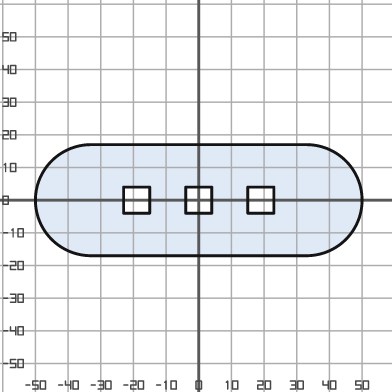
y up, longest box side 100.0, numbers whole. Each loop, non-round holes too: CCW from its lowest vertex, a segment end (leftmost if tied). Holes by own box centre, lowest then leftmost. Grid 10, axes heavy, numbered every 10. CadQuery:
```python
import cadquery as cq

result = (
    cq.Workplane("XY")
    .moveTo(-33.0, -17.0)
    .lineTo(33.0, -17.0)
    .threePointArc((50.0, 0.0), (33.0, 17.0))
    .lineTo(-33.0, 17.0)
    .threePointArc((-50.0, 0.0), (-33.0, -17.0))
    .close()
    .moveTo(-23.0, -4.0)
    .lineTo(-15.0, -4.0)
    .lineTo(-15.0, 4.0)
    .lineTo(-23.0, 4.0)
    .close()
    .moveTo(-4.0, -4.0)
    .lineTo(4.0, -4.0)
    .lineTo(4.0, 4.0)
    .lineTo(-4.0, 4.0)
    .close()
    .moveTo(15.0, -4.0)
    .lineTo(23.0, -4.0)
    .lineTo(23.0, 4.0)
    .lineTo(15.0, 4.0)
    .close()
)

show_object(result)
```